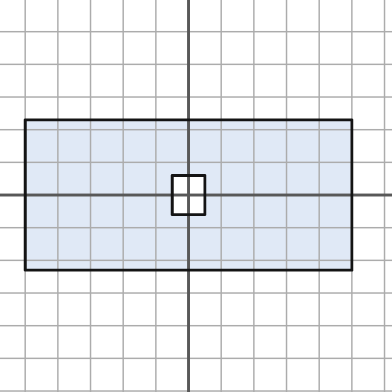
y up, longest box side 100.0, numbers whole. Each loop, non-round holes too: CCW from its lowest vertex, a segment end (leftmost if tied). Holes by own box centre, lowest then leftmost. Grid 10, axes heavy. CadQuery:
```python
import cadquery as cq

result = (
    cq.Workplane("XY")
    .moveTo(-50.0, -23.0)
    .lineTo(50.0, -23.0)
    .lineTo(50.0, 23.0)
    .lineTo(-50.0, 23.0)
    .close()
    .moveTo(-5.0, -6.0)
    .lineTo(5.0, -6.0)
    .lineTo(5.0, 6.0)
    .lineTo(-5.0, 6.0)
    .close()
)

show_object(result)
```